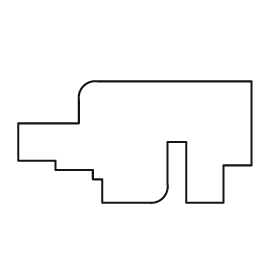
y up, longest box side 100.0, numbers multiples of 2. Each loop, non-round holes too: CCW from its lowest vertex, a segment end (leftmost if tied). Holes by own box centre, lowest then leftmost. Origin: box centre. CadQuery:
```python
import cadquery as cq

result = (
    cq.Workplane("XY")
    .moveTo(-14.0, -26.0)
    .lineTo(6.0, -26.0)
    .threePointArc((12.0, -24.0), (14.0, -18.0))
    .lineTo(14.0, 0.0)
    .lineTo(22.0, 0.0)
    .lineTo(22.0, -26.0)
    .lineTo(38.0, -26.0)
    .lineTo(38.0, -10.0)
    .lineTo(50.0, -10.0)
    .lineTo(50.0, 26.0)
    .lineTo(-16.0, 26.0)
    .threePointArc((-22.0, 24.0), (-24.0, 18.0))
    .lineTo(-24.0, 8.0)
    .lineTo(-50.0, 8.0)
    .lineTo(-50.0, -8.0)
    .lineTo(-34.0, -8.0)
    .lineTo(-34.0, -12.0)
    .lineTo(-18.0, -12.0)
    .lineTo(-18.0, -16.0)
    .lineTo(-14.0, -16.0)
    .close()
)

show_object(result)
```